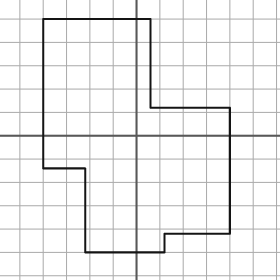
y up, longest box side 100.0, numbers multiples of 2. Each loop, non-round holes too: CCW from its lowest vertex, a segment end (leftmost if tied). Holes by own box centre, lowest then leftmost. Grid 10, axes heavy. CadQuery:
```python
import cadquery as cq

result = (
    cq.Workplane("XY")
    .moveTo(-22.0, -50.0)
    .lineTo(12.0, -50.0)
    .lineTo(12.0, -42.0)
    .lineTo(40.0, -42.0)
    .lineTo(40.0, 12.0)
    .lineTo(6.0, 12.0)
    .lineTo(6.0, 50.0)
    .lineTo(-40.0, 50.0)
    .lineTo(-40.0, -14.0)
    .lineTo(-22.0, -14.0)
    .close()
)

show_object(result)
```